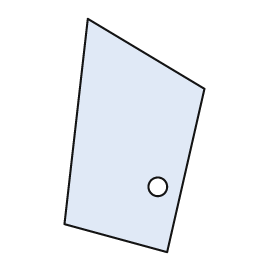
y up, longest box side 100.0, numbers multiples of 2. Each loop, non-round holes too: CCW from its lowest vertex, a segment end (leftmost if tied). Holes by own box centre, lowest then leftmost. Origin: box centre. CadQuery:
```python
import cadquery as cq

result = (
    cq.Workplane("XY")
    .moveTo(14.0, -50.0)
    .lineTo(30.0, 20.0)
    .lineTo(-20.0, 50.0)
    .lineTo(-30.0, -38.0)
    .close()
    .moveTo(10.0, -22.0)
    .circle(4.0)
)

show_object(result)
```